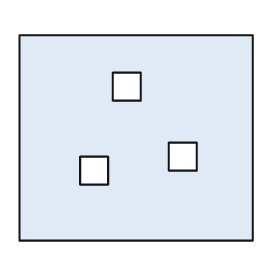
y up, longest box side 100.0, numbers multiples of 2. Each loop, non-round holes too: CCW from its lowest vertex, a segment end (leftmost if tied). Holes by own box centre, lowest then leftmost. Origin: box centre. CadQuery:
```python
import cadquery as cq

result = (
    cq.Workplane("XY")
    .moveTo(-50.0, -44.0)
    .lineTo(50.0, -44.0)
    .lineTo(50.0, 44.0)
    .lineTo(-50.0, 44.0)
    .close()
    .moveTo(-24.0, -20.0)
    .lineTo(-12.0, -20.0)
    .lineTo(-12.0, -8.0)
    .lineTo(-24.0, -8.0)
    .close()
    .moveTo(14.0, -14.0)
    .lineTo(26.0, -14.0)
    .lineTo(26.0, -2.0)
    .lineTo(14.0, -2.0)
    .close()
    .moveTo(-10.0, 16.0)
    .lineTo(2.0, 16.0)
    .lineTo(2.0, 28.0)
    .lineTo(-10.0, 28.0)
    .close()
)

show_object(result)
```